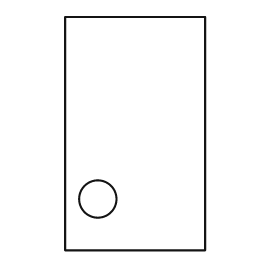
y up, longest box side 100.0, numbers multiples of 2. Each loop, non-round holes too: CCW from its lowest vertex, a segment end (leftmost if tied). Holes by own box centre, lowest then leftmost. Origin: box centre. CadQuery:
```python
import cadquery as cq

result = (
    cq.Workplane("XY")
    .moveTo(-30.0, -50.0)
    .lineTo(30.0, -50.0)
    .lineTo(30.0, 50.0)
    .lineTo(-30.0, 50.0)
    .close()
    .moveTo(-16.0, -28.0)
    .circle(8.0)
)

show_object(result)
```